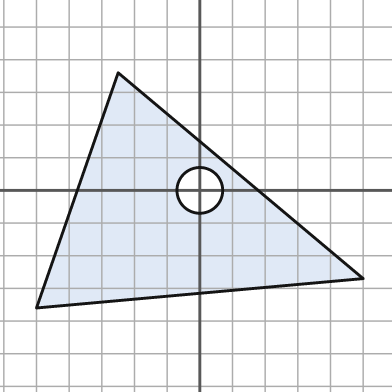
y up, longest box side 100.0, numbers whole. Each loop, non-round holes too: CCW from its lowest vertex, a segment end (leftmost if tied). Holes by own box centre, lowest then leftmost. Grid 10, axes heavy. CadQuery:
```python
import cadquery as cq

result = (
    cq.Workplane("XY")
    .moveTo(-50.0, -36.0)
    .lineTo(50.0, -27.0)
    .lineTo(-25.0, 36.0)
    .close()
    .moveTo(0.0, 0.0)
    .circle(7.0)
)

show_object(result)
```